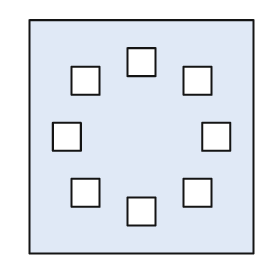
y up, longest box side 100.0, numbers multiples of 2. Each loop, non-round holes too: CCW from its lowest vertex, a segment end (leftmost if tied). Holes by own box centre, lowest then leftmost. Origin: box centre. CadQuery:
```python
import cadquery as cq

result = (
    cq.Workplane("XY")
    .moveTo(-48.0, -50.0)
    .lineTo(48.0, -50.0)
    .lineTo(48.0, 50.0)
    .lineTo(-48.0, 50.0)
    .close()
    .moveTo(-6.0, -38.0)
    .lineTo(6.0, -38.0)
    .lineTo(6.0, -26.0)
    .lineTo(-6.0, -26.0)
    .close()
    .moveTo(-30.0, -30.0)
    .lineTo(-18.0, -30.0)
    .lineTo(-18.0, -18.0)
    .lineTo(-30.0, -18.0)
    .close()
    .moveTo(18.0, -30.0)
    .lineTo(30.0, -30.0)
    .lineTo(30.0, -18.0)
    .lineTo(18.0, -18.0)
    .close()
    .moveTo(-38.0, -6.0)
    .lineTo(-26.0, -6.0)
    .lineTo(-26.0, 6.0)
    .lineTo(-38.0, 6.0)
    .close()
    .moveTo(26.0, -6.0)
    .lineTo(38.0, -6.0)
    .lineTo(38.0, 6.0)
    .lineTo(26.0, 6.0)
    .close()
    .moveTo(-30.0, 18.0)
    .lineTo(-18.0, 18.0)
    .lineTo(-18.0, 30.0)
    .lineTo(-30.0, 30.0)
    .close()
    .moveTo(18.0, 18.0)
    .lineTo(30.0, 18.0)
    .lineTo(30.0, 30.0)
    .lineTo(18.0, 30.0)
    .close()
    .moveTo(-6.0, 26.0)
    .lineTo(6.0, 26.0)
    .lineTo(6.0, 38.0)
    .lineTo(-6.0, 38.0)
    .close()
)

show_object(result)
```